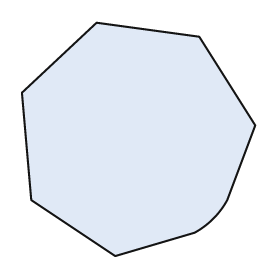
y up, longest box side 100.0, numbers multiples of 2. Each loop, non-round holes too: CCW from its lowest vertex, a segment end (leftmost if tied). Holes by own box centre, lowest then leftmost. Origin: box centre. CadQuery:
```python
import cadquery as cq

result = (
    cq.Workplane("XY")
    .moveTo(-10.0, -50.0)
    .lineTo(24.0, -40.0)
    .threePointArc((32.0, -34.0), (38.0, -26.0))
    .lineTo(50.0, 6.0)
    .lineTo(26.0, 44.0)
    .lineTo(-18.0, 50.0)
    .lineTo(-50.0, 20.0)
    .lineTo(-46.0, -26.0)
    .close()
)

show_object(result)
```